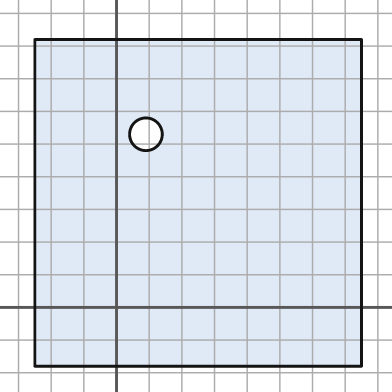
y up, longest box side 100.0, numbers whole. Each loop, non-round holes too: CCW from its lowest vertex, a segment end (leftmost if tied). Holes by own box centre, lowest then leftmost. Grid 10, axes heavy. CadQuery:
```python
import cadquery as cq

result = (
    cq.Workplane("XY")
    .moveTo(-25.0, -18.0)
    .lineTo(75.0, -18.0)
    .lineTo(75.0, 82.0)
    .lineTo(-25.0, 82.0)
    .close()
    .moveTo(9.0, 53.0)
    .circle(5.0)
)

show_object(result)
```